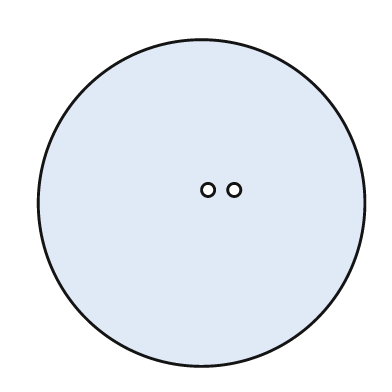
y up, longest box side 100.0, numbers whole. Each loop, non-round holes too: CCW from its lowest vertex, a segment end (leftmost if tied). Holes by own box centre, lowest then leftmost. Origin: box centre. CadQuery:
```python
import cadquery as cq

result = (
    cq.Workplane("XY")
    .moveTo(0.0, 0.0)
    .circle(50.0)
    .moveTo(2.0, 4.0)
    .circle(2.0)
    .moveTo(10.0, 4.0)
    .circle(2.0)
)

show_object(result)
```